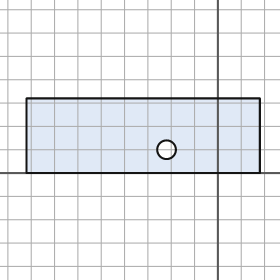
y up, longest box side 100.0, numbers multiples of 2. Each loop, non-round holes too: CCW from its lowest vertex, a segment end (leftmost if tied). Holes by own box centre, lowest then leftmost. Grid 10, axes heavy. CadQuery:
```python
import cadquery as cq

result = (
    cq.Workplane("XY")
    .moveTo(-82.0, 0.0)
    .lineTo(18.0, 0.0)
    .lineTo(18.0, 32.0)
    .lineTo(-82.0, 32.0)
    .close()
    .moveTo(-22.0, 10.0)
    .circle(4.0)
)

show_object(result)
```